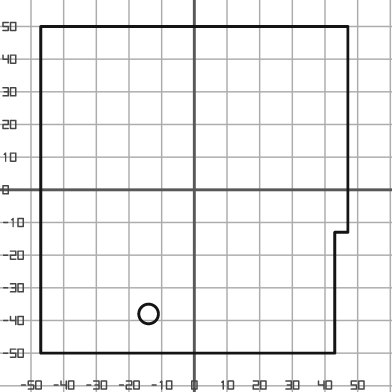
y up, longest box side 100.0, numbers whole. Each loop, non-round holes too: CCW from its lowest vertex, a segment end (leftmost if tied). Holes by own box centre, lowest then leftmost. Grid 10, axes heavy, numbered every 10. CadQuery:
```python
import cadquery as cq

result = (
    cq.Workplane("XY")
    .moveTo(-47.0, -50.0)
    .lineTo(43.0, -50.0)
    .lineTo(43.0, -13.0)
    .lineTo(47.0, -13.0)
    .lineTo(47.0, 50.0)
    .lineTo(-47.0, 50.0)
    .close()
    .moveTo(-14.0, -38.0)
    .circle(3.0)
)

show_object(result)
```